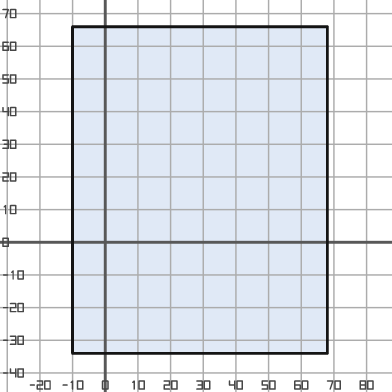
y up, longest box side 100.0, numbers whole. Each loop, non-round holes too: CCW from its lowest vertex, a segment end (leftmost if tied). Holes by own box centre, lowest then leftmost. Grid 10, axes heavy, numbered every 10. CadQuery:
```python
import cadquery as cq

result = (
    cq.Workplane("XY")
    .moveTo(-10.0, -34.0)
    .lineTo(68.0, -34.0)
    .lineTo(68.0, 66.0)
    .lineTo(-10.0, 66.0)
    .close()
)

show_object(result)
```